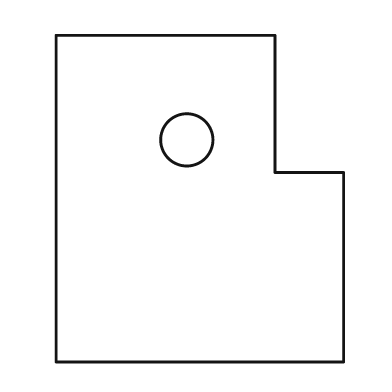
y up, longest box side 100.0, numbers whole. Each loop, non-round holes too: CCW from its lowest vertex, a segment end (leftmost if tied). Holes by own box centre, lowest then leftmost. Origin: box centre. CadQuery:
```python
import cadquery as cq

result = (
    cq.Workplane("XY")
    .moveTo(-44.0, -50.0)
    .lineTo(44.0, -50.0)
    .lineTo(44.0, 8.0)
    .lineTo(23.0, 8.0)
    .lineTo(23.0, 50.0)
    .lineTo(-44.0, 50.0)
    .close()
    .moveTo(-4.0, 18.0)
    .circle(8.0)
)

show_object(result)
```